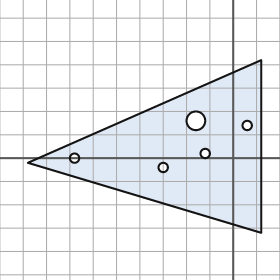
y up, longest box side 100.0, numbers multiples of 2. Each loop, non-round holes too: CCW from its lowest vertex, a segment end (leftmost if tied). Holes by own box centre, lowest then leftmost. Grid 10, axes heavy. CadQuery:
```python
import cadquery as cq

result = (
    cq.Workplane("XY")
    .moveTo(12.0, -32.0)
    .lineTo(12.0, 42.0)
    .lineTo(-88.0, -2.0)
    .close()
    .moveTo(-30.0, -4.0)
    .circle(2.0)
    .moveTo(-68.0, 0.0)
    .circle(2.0)
    .moveTo(-12.0, 2.0)
    .circle(2.0)
    .moveTo(6.0, 14.0)
    .circle(2.0)
    .moveTo(-16.0, 16.0)
    .circle(4.0)
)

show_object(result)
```